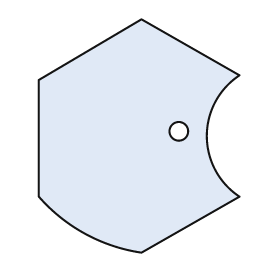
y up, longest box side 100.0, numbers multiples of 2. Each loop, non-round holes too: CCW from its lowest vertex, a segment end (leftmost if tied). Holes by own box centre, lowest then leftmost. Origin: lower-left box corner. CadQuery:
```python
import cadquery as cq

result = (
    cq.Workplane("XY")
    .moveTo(44.0, 0.0)
    .lineTo(86.0, 24.0)
    .threePointArc((72.0, 50.0), (86.0, 76.0))
    .lineTo(44.0, 100.0)
    .lineTo(0.0, 74.0)
    .lineTo(0.0, 24.0)
    .threePointArc((20.0, 8.0), (44.0, 0.0))
    .close()
    .moveTo(60.0, 52.0)
    .circle(4.0)
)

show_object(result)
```